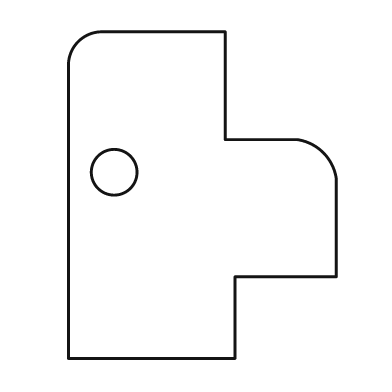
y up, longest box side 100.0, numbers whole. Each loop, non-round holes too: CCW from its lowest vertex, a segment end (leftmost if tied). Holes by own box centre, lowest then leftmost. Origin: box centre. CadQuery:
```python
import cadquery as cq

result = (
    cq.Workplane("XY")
    .moveTo(-41.0, -50.0)
    .lineTo(10.0, -50.0)
    .lineTo(10.0, -25.0)
    .lineTo(41.0, -25.0)
    .lineTo(41.0, 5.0)
    .threePointArc((37.0, 13.0), (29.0, 17.0))
    .lineTo(7.0, 17.0)
    .lineTo(7.0, 50.0)
    .lineTo(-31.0, 50.0)
    .threePointArc((-38.0, 47.0), (-41.0, 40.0))
    .close()
    .moveTo(-27.0, 7.0)
    .circle(7.0)
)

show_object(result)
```